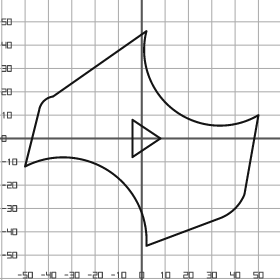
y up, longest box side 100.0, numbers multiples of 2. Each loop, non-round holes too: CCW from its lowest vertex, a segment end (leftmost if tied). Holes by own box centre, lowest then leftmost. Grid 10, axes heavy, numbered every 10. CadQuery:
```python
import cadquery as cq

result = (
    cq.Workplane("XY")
    .moveTo(2.0, -46.0)
    .lineTo(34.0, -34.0)
    .threePointArc((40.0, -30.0), (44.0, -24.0))
    .lineTo(50.0, 10.0)
    .threePointArc((14.0, 12.0), (2.0, 46.0))
    .lineTo(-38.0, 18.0)
    .threePointArc((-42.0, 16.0), (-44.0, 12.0))
    .lineTo(-50.0, -12.0)
    .threePointArc((-14.0, -14.0), (2.0, -46.0))
    .close()
    .moveTo(-4.0, -8.0)
    .lineTo(8.0, 0.0)
    .lineTo(-4.0, 8.0)
    .close()
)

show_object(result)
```